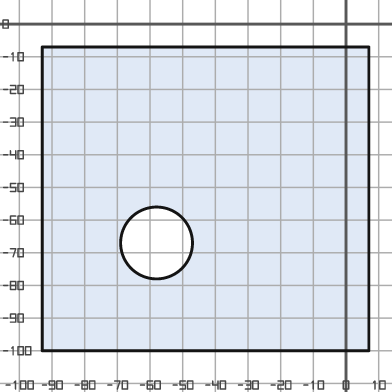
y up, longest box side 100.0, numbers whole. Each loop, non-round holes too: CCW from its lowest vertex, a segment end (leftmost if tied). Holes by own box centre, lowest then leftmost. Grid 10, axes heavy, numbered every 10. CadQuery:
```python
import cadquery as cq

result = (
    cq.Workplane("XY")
    .moveTo(-93.0, -100.0)
    .lineTo(7.0, -100.0)
    .lineTo(7.0, -7.0)
    .lineTo(-93.0, -7.0)
    .close()
    .moveTo(-58.0, -67.0)
    .circle(11.0)
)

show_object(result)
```